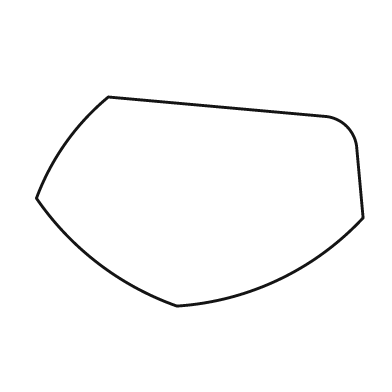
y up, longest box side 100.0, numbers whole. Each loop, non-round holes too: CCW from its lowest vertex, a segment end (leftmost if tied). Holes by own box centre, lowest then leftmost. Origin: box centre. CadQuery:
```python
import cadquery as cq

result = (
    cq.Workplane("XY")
    .moveTo(-7.0, -32.0)
    .threePointArc((24.0, -24.0), (50.0, -5.0))
    .lineTo(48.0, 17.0)
    .threePointArc((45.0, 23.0), (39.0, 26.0))
    .lineTo(-28.0, 32.0)
    .threePointArc((-41.0, 18.0), (-50.0, 1.0))
    .threePointArc((-31.0, -19.0), (-7.0, -32.0))
    .close()
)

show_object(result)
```